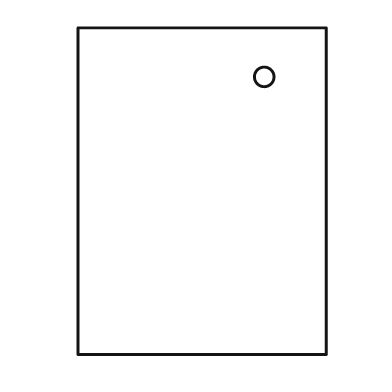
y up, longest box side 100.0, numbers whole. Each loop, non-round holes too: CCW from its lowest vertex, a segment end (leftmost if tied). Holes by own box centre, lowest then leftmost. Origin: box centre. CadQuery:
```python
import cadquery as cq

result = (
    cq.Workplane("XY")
    .moveTo(-38.0, -50.0)
    .lineTo(38.0, -50.0)
    .lineTo(38.0, 50.0)
    .lineTo(-38.0, 50.0)
    .close()
    .moveTo(19.0, 35.0)
    .circle(3.0)
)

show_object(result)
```